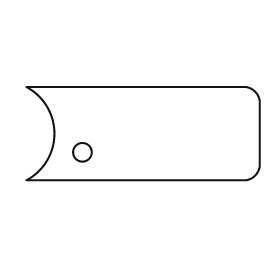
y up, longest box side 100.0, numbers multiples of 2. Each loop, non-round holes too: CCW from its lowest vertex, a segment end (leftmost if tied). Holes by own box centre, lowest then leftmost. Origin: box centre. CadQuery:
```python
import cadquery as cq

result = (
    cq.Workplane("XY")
    .moveTo(-50.0, -20.0)
    .lineTo(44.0, -20.0)
    .threePointArc((48.0, -18.0), (50.0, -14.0))
    .lineTo(50.0, 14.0)
    .threePointArc((48.0, 18.0), (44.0, 20.0))
    .lineTo(-50.0, 20.0)
    .threePointArc((-38.0, 0.0), (-50.0, -20.0))
    .close()
    .moveTo(-26.0, -8.0)
    .circle(4.0)
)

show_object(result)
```